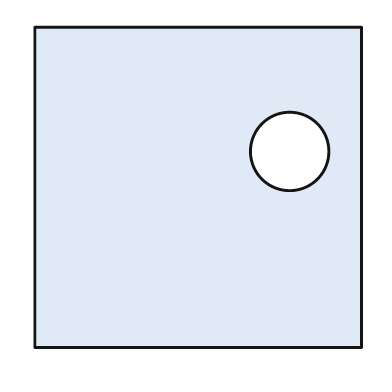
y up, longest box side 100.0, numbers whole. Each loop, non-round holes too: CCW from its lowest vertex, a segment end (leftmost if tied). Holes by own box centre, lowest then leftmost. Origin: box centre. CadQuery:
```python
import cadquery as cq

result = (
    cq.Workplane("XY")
    .moveTo(-50.0, -49.0)
    .lineTo(50.0, -49.0)
    .lineTo(50.0, 49.0)
    .lineTo(-50.0, 49.0)
    .close()
    .moveTo(28.0, 11.0)
    .circle(12.0)
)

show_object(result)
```